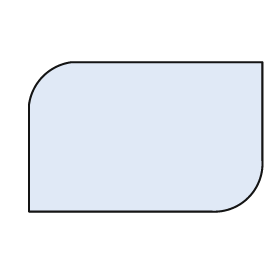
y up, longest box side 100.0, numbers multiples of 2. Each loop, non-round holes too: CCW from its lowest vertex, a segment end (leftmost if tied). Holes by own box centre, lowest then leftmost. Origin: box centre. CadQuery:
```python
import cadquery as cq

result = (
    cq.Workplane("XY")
    .moveTo(-50.0, -32.0)
    .lineTo(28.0, -32.0)
    .threePointArc((44.0, -26.0), (50.0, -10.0))
    .lineTo(50.0, 32.0)
    .lineTo(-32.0, 32.0)
    .threePointArc((-44.0, 26.0), (-50.0, 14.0))
    .close()
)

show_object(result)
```